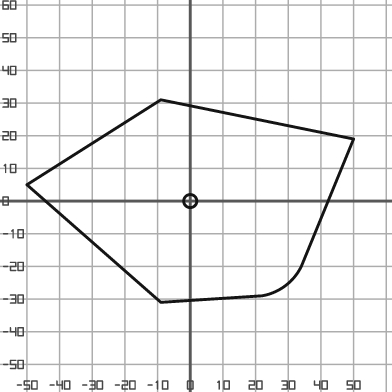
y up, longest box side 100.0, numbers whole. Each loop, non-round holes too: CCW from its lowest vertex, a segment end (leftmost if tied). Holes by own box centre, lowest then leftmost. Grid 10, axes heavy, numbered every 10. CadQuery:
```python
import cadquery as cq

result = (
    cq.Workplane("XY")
    .moveTo(-9.0, -31.0)
    .lineTo(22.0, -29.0)
    .threePointArc((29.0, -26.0), (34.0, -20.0))
    .lineTo(50.0, 19.0)
    .lineTo(-9.0, 31.0)
    .lineTo(-50.0, 5.0)
    .close()
    .moveTo(0.0, 0.0)
    .circle(2.0)
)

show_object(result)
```